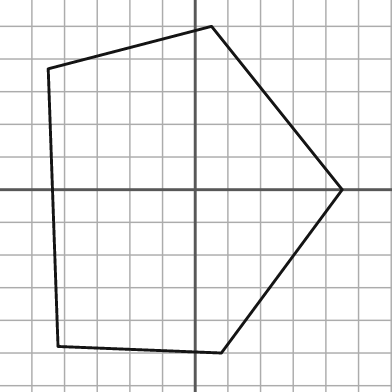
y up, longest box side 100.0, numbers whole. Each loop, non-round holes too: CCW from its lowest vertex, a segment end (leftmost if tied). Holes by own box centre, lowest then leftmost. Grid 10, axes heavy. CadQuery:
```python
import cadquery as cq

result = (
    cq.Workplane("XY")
    .moveTo(8.0, -50.0)
    .lineTo(45.0, 0.0)
    .lineTo(5.0, 50.0)
    .lineTo(-45.0, 37.0)
    .lineTo(-42.0, -48.0)
    .close()
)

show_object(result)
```